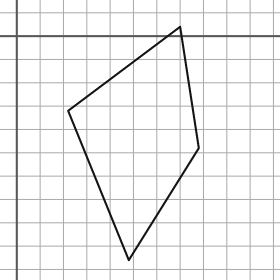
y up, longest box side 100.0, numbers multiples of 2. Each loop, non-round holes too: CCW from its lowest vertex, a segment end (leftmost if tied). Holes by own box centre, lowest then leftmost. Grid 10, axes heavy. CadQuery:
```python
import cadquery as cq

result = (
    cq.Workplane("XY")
    .moveTo(48.0, -96.0)
    .lineTo(78.0, -48.0)
    .lineTo(70.0, 4.0)
    .lineTo(22.0, -32.0)
    .close()
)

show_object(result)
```